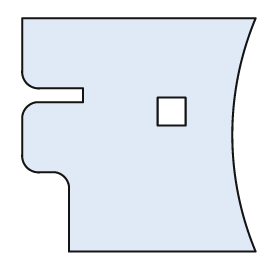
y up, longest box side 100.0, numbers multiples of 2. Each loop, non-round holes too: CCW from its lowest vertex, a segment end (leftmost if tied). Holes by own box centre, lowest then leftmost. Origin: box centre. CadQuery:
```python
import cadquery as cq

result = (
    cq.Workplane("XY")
    .moveTo(-30.0, -50.0)
    .lineTo(50.0, -50.0)
    .threePointArc((40.0, 0.0), (50.0, 50.0))
    .lineTo(-50.0, 50.0)
    .lineTo(-50.0, 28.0)
    .threePointArc((-48.0, 22.0), (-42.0, 20.0))
    .lineTo(-24.0, 20.0)
    .lineTo(-24.0, 14.0)
    .lineTo(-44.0, 14.0)
    .threePointArc((-48.0, 12.0), (-50.0, 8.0))
    .lineTo(-50.0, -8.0)
    .threePointArc((-48.0, -14.0), (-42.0, -16.0))
    .lineTo(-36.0, -16.0)
    .threePointArc((-32.0, -18.0), (-30.0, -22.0))
    .close()
    .moveTo(8.0, 4.0)
    .lineTo(20.0, 4.0)
    .lineTo(20.0, 16.0)
    .lineTo(8.0, 16.0)
    .close()
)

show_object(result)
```